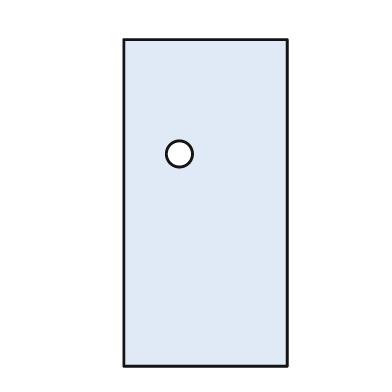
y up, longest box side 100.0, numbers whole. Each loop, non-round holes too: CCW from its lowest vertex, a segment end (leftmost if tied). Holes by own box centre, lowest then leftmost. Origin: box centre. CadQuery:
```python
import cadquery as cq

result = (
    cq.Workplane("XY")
    .moveTo(-25.0, -50.0)
    .lineTo(25.0, -50.0)
    .lineTo(25.0, 50.0)
    .lineTo(-25.0, 50.0)
    .close()
    .moveTo(-8.0, 15.0)
    .circle(4.0)
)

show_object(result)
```